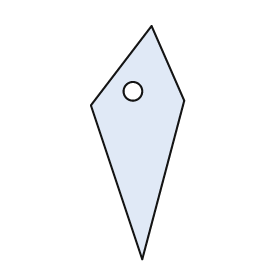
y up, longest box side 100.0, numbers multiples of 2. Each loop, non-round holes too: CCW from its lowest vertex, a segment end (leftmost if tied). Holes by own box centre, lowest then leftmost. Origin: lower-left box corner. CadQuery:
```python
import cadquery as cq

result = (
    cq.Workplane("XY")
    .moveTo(22.0, 0.0)
    .lineTo(40.0, 68.0)
    .lineTo(26.0, 100.0)
    .lineTo(0.0, 66.0)
    .close()
    .moveTo(18.0, 72.0)
    .circle(4.0)
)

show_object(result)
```